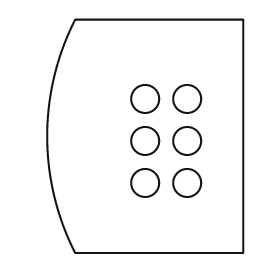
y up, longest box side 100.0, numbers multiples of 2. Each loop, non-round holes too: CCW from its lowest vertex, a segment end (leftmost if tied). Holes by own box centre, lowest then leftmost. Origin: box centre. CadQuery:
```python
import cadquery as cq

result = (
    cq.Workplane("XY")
    .moveTo(-30.0, -50.0)
    .lineTo(42.0, -50.0)
    .lineTo(42.0, 50.0)
    .lineTo(-30.0, 50.0)
    .threePointArc((-42.0, 0.0), (-30.0, -50.0))
    .close()
    .moveTo(0.0, -20.0)
    .circle(6.0)
    .moveTo(18.0, -20.0)
    .circle(6.0)
    .moveTo(0.0, -2.0)
    .circle(6.0)
    .moveTo(18.0, -2.0)
    .circle(6.0)
    .moveTo(0.0, 16.0)
    .circle(6.0)
    .moveTo(18.0, 16.0)
    .circle(6.0)
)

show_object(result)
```